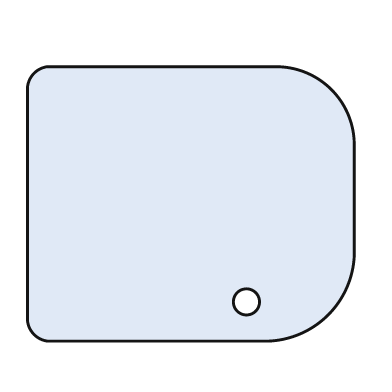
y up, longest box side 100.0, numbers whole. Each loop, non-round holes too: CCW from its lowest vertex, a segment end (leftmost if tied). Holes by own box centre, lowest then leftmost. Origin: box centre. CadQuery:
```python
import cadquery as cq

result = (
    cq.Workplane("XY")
    .moveTo(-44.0, -42.0)
    .lineTo(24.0, -42.0)
    .threePointArc((42.0, -34.0), (50.0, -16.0))
    .lineTo(50.0, 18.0)
    .threePointArc((43.0, 35.0), (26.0, 42.0))
    .lineTo(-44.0, 42.0)
    .threePointArc((-48.0, 40.0), (-50.0, 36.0))
    .lineTo(-50.0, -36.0)
    .threePointArc((-48.0, -40.0), (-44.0, -42.0))
    .close()
    .moveTo(17.0, -30.0)
    .circle(4.0)
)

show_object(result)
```